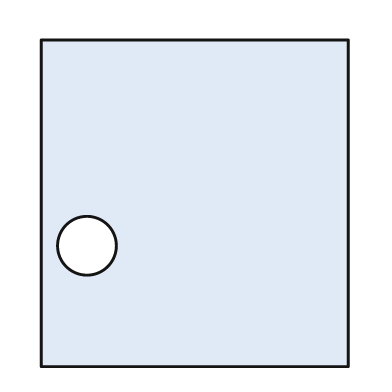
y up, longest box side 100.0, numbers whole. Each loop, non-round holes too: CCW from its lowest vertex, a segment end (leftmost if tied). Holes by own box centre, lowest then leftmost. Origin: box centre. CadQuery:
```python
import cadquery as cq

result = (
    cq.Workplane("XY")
    .moveTo(-47.0, -50.0)
    .lineTo(47.0, -50.0)
    .lineTo(47.0, 50.0)
    .lineTo(-47.0, 50.0)
    .close()
    .moveTo(-33.0, -13.0)
    .circle(9.0)
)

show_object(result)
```